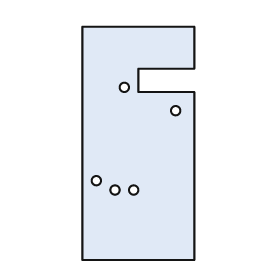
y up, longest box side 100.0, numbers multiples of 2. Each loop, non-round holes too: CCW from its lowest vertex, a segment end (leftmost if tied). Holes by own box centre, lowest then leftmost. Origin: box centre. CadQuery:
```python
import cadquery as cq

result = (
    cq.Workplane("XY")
    .moveTo(-24.0, -50.0)
    .lineTo(24.0, -50.0)
    .lineTo(24.0, 22.0)
    .lineTo(0.0, 22.0)
    .lineTo(0.0, 32.0)
    .lineTo(24.0, 32.0)
    .lineTo(24.0, 50.0)
    .lineTo(-24.0, 50.0)
    .close()
    .moveTo(-10.0, -20.0)
    .circle(2.0)
    .moveTo(-2.0, -20.0)
    .circle(2.0)
    .moveTo(-18.0, -16.0)
    .circle(2.0)
    .moveTo(16.0, 14.0)
    .circle(2.0)
    .moveTo(-6.0, 24.0)
    .circle(2.0)
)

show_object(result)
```